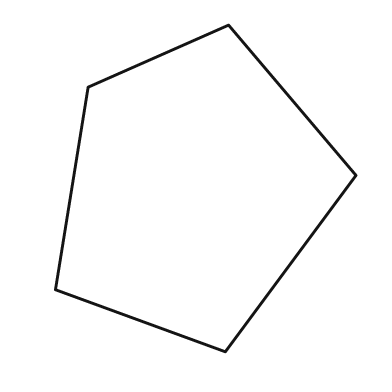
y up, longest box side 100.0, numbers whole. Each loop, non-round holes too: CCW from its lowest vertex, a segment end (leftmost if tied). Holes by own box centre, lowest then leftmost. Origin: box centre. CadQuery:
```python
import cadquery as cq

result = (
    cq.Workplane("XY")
    .moveTo(6.0, -50.0)
    .lineTo(46.0, 4.0)
    .lineTo(7.0, 50.0)
    .lineTo(-36.0, 31.0)
    .lineTo(-46.0, -31.0)
    .close()
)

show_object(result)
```